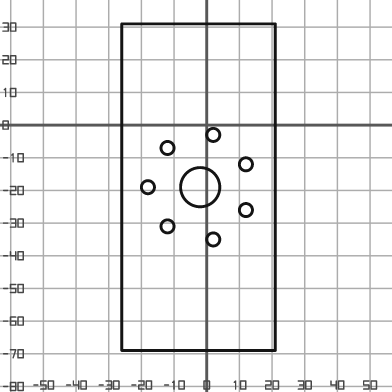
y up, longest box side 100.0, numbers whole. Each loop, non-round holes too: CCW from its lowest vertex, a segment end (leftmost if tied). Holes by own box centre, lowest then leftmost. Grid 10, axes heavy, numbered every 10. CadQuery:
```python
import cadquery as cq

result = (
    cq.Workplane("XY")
    .moveTo(-26.0, -69.0)
    .lineTo(21.0, -69.0)
    .lineTo(21.0, 31.0)
    .lineTo(-26.0, 31.0)
    .close()
    .moveTo(2.0, -35.0)
    .circle(2.0)
    .moveTo(-12.0, -31.0)
    .circle(2.0)
    .moveTo(12.0, -26.0)
    .circle(2.0)
    .moveTo(-18.0, -19.0)
    .circle(2.0)
    .moveTo(-2.0, -19.0)
    .circle(6.0)
    .moveTo(12.0, -12.0)
    .circle(2.0)
    .moveTo(-12.0, -7.0)
    .circle(2.0)
    .moveTo(2.0, -3.0)
    .circle(2.0)
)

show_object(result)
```